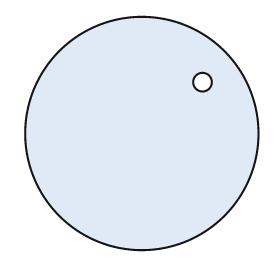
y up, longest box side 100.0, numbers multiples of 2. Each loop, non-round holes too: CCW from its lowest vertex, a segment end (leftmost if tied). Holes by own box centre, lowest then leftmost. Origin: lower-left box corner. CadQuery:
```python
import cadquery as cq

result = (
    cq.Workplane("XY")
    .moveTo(50.0, 50.0)
    .circle(50.0)
    .moveTo(76.0, 72.0)
    .circle(4.0)
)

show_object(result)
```